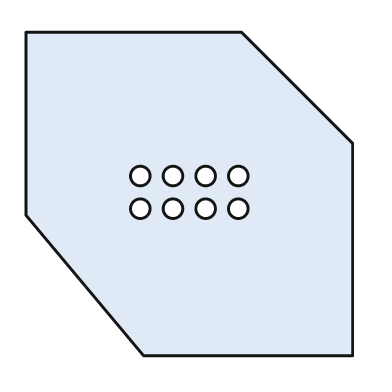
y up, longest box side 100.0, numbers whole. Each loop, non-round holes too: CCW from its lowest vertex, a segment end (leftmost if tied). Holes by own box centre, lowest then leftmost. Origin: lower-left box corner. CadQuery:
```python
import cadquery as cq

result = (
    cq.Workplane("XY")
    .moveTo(36.0, 0.0)
    .lineTo(100.0, 0.0)
    .lineTo(100.0, 65.0)
    .lineTo(66.0, 99.0)
    .lineTo(0.0, 99.0)
    .lineTo(0.0, 43.0)
    .close()
    .moveTo(35.0, 45.0)
    .circle(3.0)
    .moveTo(45.0, 45.0)
    .circle(3.0)
    .moveTo(55.0, 45.0)
    .circle(3.0)
    .moveTo(65.0, 45.0)
    .circle(3.0)
    .moveTo(35.0, 55.0)
    .circle(3.0)
    .moveTo(45.0, 55.0)
    .circle(3.0)
    .moveTo(55.0, 55.0)
    .circle(3.0)
    .moveTo(65.0, 55.0)
    .circle(3.0)
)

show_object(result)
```